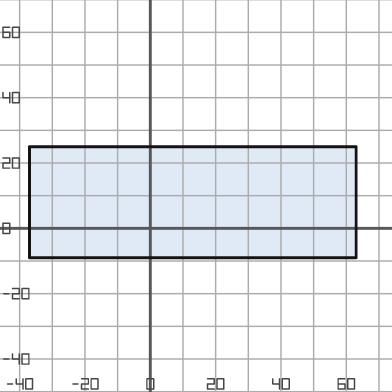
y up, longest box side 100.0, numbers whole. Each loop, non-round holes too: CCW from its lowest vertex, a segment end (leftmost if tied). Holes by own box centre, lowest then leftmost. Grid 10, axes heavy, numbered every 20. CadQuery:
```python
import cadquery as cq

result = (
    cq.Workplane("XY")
    .moveTo(-37.0, -9.0)
    .lineTo(63.0, -9.0)
    .lineTo(63.0, 25.0)
    .lineTo(-37.0, 25.0)
    .close()
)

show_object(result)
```